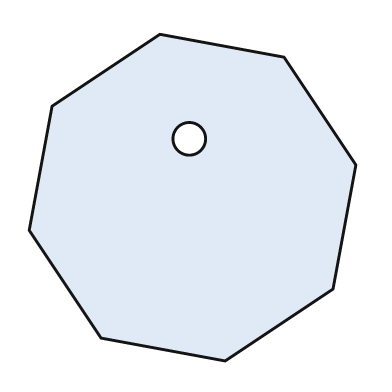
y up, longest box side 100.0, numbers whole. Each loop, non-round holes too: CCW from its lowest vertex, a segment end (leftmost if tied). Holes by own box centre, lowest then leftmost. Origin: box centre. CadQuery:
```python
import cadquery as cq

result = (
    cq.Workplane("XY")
    .moveTo(10.0, -50.0)
    .lineTo(43.0, -28.0)
    .lineTo(50.0, 10.0)
    .lineTo(28.0, 43.0)
    .lineTo(-10.0, 50.0)
    .lineTo(-43.0, 28.0)
    .lineTo(-50.0, -10.0)
    .lineTo(-28.0, -43.0)
    .close()
    .moveTo(-1.0, 18.0)
    .circle(5.0)
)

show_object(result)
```